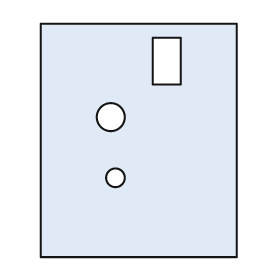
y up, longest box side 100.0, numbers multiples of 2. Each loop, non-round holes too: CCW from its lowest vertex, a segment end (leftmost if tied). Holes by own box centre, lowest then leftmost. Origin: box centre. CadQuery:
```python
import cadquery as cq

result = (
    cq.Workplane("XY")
    .moveTo(-42.0, -50.0)
    .lineTo(42.0, -50.0)
    .lineTo(42.0, 50.0)
    .lineTo(-42.0, 50.0)
    .close()
    .moveTo(-10.0, -16.0)
    .circle(4.0)
    .moveTo(-12.0, 10.0)
    .circle(6.0)
    .moveTo(6.0, 24.0)
    .lineTo(18.0, 24.0)
    .lineTo(18.0, 44.0)
    .lineTo(6.0, 44.0)
    .close()
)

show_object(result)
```